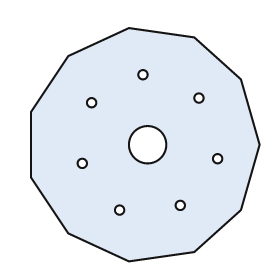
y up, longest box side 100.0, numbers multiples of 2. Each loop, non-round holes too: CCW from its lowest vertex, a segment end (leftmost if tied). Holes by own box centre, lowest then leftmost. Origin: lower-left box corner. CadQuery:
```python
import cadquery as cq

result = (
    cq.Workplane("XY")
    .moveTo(42.0, 0.0)
    .lineTo(70.0, 4.0)
    .lineTo(90.0, 22.0)
    .lineTo(98.0, 50.0)
    .lineTo(90.0, 78.0)
    .lineTo(70.0, 96.0)
    .lineTo(42.0, 100.0)
    .lineTo(16.0, 88.0)
    .lineTo(0.0, 64.0)
    .lineTo(0.0, 36.0)
    .lineTo(16.0, 12.0)
    .close()
    .moveTo(38.0, 22.0)
    .circle(2.0)
    .moveTo(64.0, 24.0)
    .circle(2.0)
    .moveTo(22.0, 42.0)
    .circle(2.0)
    .moveTo(80.0, 44.0)
    .circle(2.0)
    .moveTo(50.0, 50.0)
    .circle(8.0)
    .moveTo(26.0, 68.0)
    .circle(2.0)
    .moveTo(72.0, 70.0)
    .circle(2.0)
    .moveTo(48.0, 80.0)
    .circle(2.0)
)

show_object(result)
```